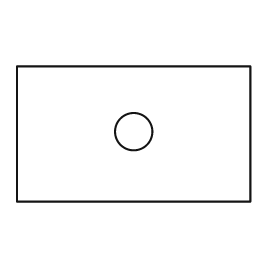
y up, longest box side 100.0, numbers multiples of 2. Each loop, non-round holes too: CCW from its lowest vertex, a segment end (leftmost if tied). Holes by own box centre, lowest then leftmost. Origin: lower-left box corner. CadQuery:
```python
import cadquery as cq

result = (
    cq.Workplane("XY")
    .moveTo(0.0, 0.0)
    .lineTo(100.0, 0.0)
    .lineTo(100.0, 58.0)
    .lineTo(0.0, 58.0)
    .close()
    .moveTo(50.0, 30.0)
    .circle(8.0)
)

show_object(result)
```